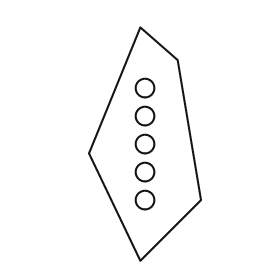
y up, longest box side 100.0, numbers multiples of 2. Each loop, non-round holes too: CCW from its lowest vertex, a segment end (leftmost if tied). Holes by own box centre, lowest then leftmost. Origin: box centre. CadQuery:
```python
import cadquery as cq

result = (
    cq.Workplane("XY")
    .moveTo(-2.0, -50.0)
    .lineTo(24.0, -24.0)
    .lineTo(14.0, 36.0)
    .lineTo(-2.0, 50.0)
    .lineTo(-24.0, -4.0)
    .close()
    .moveTo(0.0, -24.0)
    .circle(4.0)
    .moveTo(0.0, -12.0)
    .circle(4.0)
    .moveTo(0.0, 0.0)
    .circle(4.0)
    .moveTo(0.0, 12.0)
    .circle(4.0)
    .moveTo(0.0, 24.0)
    .circle(4.0)
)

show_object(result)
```